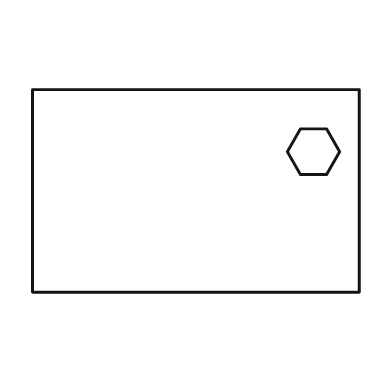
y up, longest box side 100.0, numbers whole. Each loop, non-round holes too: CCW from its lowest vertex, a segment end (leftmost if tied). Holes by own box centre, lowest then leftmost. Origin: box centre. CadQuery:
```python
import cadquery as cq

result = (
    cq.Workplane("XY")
    .moveTo(-50.0, -31.0)
    .lineTo(50.0, -31.0)
    .lineTo(50.0, 31.0)
    .lineTo(-50.0, 31.0)
    .close()
    .moveTo(32.0, 5.0)
    .lineTo(40.0, 5.0)
    .lineTo(44.0, 12.0)
    .lineTo(40.0, 19.0)
    .lineTo(32.0, 19.0)
    .lineTo(28.0, 12.0)
    .close()
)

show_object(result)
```